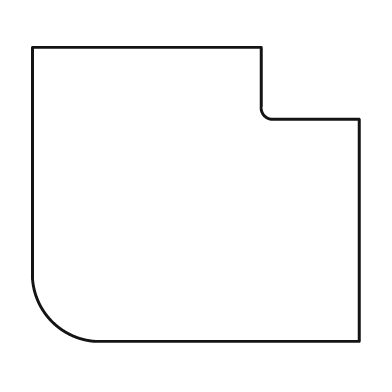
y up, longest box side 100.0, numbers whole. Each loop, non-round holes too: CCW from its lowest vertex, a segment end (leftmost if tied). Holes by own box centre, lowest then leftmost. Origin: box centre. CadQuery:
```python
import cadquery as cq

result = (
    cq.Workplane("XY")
    .moveTo(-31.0, -45.0)
    .lineTo(50.0, -45.0)
    .lineTo(50.0, 23.0)
    .lineTo(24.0, 23.0)
    .threePointArc((21.0, 24.0), (20.0, 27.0))
    .lineTo(20.0, 45.0)
    .lineTo(-50.0, 45.0)
    .lineTo(-50.0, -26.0)
    .threePointArc((-44.0, -39.0), (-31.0, -45.0))
    .close()
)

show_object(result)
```